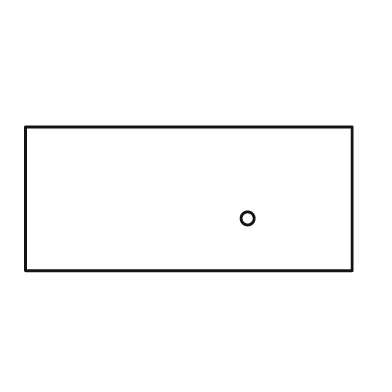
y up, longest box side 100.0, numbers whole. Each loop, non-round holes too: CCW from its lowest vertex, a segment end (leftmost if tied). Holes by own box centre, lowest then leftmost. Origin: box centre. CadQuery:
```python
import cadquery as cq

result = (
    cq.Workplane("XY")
    .moveTo(-50.0, -22.0)
    .lineTo(50.0, -22.0)
    .lineTo(50.0, 22.0)
    .lineTo(-50.0, 22.0)
    .close()
    .moveTo(18.0, -6.0)
    .circle(2.0)
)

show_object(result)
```